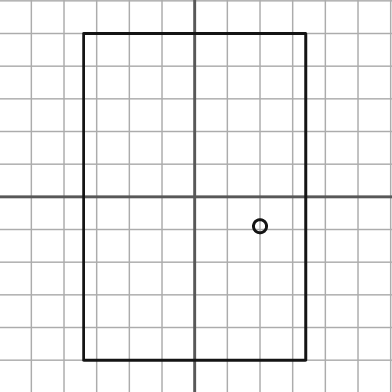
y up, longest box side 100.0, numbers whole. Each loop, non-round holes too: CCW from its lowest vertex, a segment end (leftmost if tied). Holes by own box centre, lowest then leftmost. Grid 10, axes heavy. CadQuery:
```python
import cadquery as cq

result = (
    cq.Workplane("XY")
    .moveTo(-34.0, -50.0)
    .lineTo(34.0, -50.0)
    .lineTo(34.0, 50.0)
    .lineTo(-34.0, 50.0)
    .close()
    .moveTo(20.0, -9.0)
    .circle(2.0)
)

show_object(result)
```